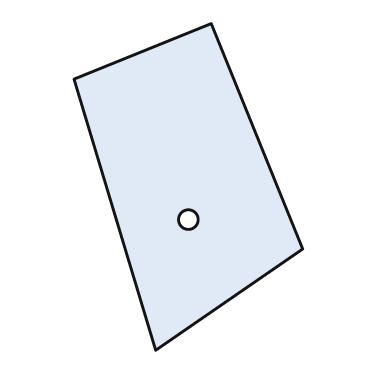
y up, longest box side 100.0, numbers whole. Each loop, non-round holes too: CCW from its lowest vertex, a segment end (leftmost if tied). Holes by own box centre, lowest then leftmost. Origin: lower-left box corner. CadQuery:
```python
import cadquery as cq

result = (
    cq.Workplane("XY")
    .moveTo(25.0, 0.0)
    .lineTo(70.0, 31.0)
    .lineTo(42.0, 100.0)
    .lineTo(0.0, 83.0)
    .close()
    .moveTo(35.0, 40.0)
    .circle(3.0)
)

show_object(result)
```